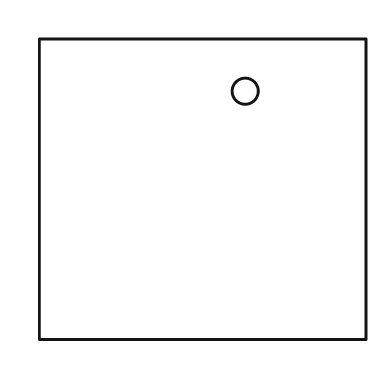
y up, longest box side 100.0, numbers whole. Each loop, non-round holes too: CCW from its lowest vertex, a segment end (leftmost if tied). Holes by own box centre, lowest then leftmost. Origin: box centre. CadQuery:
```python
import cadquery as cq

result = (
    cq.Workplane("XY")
    .moveTo(-50.0, -46.0)
    .lineTo(50.0, -46.0)
    .lineTo(50.0, 46.0)
    .lineTo(-50.0, 46.0)
    .close()
    .moveTo(13.0, 30.0)
    .circle(4.0)
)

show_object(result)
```